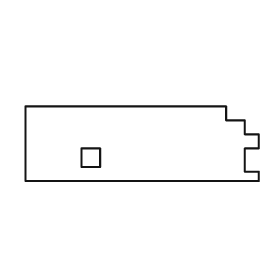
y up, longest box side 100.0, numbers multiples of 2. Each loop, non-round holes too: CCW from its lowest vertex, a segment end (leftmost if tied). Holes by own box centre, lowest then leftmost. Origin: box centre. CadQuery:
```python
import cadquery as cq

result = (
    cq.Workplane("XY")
    .moveTo(-50.0, -16.0)
    .lineTo(50.0, -16.0)
    .lineTo(50.0, -12.0)
    .lineTo(44.0, -12.0)
    .lineTo(44.0, -2.0)
    .lineTo(50.0, -2.0)
    .lineTo(50.0, 4.0)
    .lineTo(44.0, 4.0)
    .lineTo(44.0, 10.0)
    .lineTo(36.0, 10.0)
    .lineTo(36.0, 16.0)
    .lineTo(-50.0, 16.0)
    .close()
    .moveTo(-26.0, -10.0)
    .lineTo(-18.0, -10.0)
    .lineTo(-18.0, -2.0)
    .lineTo(-26.0, -2.0)
    .close()
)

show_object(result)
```